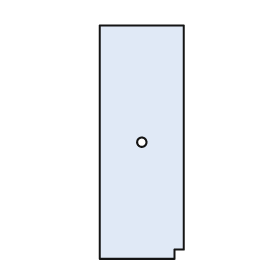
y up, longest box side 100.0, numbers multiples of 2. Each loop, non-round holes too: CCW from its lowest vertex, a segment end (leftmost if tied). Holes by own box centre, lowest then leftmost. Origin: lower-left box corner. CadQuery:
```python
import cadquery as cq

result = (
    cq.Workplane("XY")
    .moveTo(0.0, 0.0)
    .lineTo(32.0, 0.0)
    .lineTo(32.0, 4.0)
    .lineTo(36.0, 4.0)
    .lineTo(36.0, 100.0)
    .lineTo(0.0, 100.0)
    .close()
    .moveTo(18.0, 50.0)
    .circle(2.0)
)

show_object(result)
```